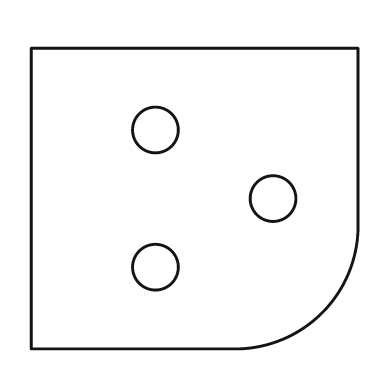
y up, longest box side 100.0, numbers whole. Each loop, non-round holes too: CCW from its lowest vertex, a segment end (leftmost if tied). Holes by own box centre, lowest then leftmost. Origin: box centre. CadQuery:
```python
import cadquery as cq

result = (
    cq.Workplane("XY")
    .moveTo(-50.0, -46.0)
    .lineTo(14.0, -46.0)
    .threePointArc((39.0, -35.0), (50.0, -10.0))
    .lineTo(50.0, 46.0)
    .lineTo(-50.0, 46.0)
    .close()
    .moveTo(-12.0, -21.0)
    .circle(7.0)
    .moveTo(24.0, 0.0)
    .circle(7.0)
    .moveTo(-12.0, 21.0)
    .circle(7.0)
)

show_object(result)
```